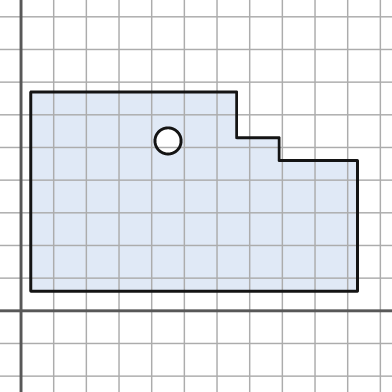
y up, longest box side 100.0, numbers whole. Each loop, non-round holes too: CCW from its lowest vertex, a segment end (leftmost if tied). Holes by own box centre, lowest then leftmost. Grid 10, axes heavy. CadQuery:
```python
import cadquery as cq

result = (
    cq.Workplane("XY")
    .moveTo(3.0, 6.0)
    .lineTo(103.0, 6.0)
    .lineTo(103.0, 46.0)
    .lineTo(79.0, 46.0)
    .lineTo(79.0, 53.0)
    .lineTo(66.0, 53.0)
    .lineTo(66.0, 67.0)
    .lineTo(3.0, 67.0)
    .close()
    .moveTo(45.0, 52.0)
    .circle(4.0)
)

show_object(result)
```